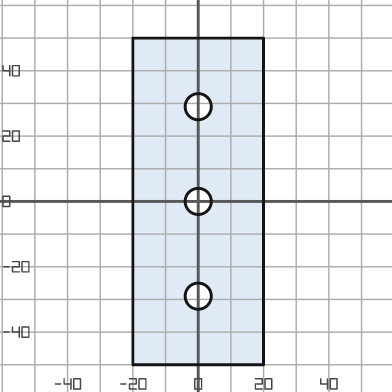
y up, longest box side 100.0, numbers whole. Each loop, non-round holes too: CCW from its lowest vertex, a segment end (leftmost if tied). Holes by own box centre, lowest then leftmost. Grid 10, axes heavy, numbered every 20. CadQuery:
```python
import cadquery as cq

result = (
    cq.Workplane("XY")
    .moveTo(-20.0, -50.0)
    .lineTo(20.0, -50.0)
    .lineTo(20.0, 50.0)
    .lineTo(-20.0, 50.0)
    .close()
    .moveTo(0.0, -29.0)
    .circle(4.0)
    .moveTo(0.0, 0.0)
    .circle(4.0)
    .moveTo(0.0, 29.0)
    .circle(4.0)
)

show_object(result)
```